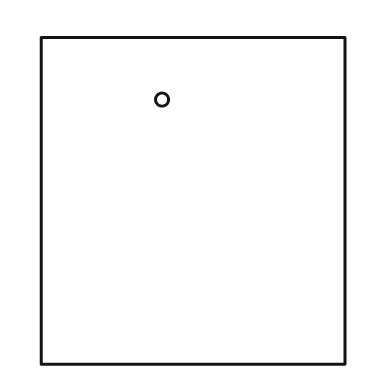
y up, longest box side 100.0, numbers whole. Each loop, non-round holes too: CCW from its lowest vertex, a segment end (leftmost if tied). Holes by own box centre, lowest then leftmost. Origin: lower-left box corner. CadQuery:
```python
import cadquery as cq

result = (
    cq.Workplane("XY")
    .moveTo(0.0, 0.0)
    .lineTo(93.0, 0.0)
    .lineTo(93.0, 100.0)
    .lineTo(0.0, 100.0)
    .close()
    .moveTo(37.0, 81.0)
    .circle(2.0)
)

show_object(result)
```